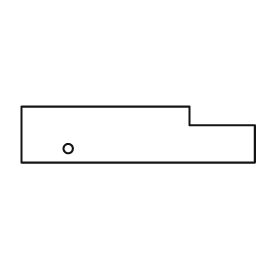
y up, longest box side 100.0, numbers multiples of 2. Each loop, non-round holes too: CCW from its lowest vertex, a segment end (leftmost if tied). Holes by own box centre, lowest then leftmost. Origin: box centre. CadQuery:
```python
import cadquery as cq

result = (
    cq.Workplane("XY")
    .moveTo(-50.0, -12.0)
    .lineTo(50.0, -12.0)
    .lineTo(50.0, 4.0)
    .lineTo(22.0, 4.0)
    .lineTo(22.0, 12.0)
    .lineTo(-50.0, 12.0)
    .close()
    .moveTo(-30.0, -6.0)
    .circle(2.0)
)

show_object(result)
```